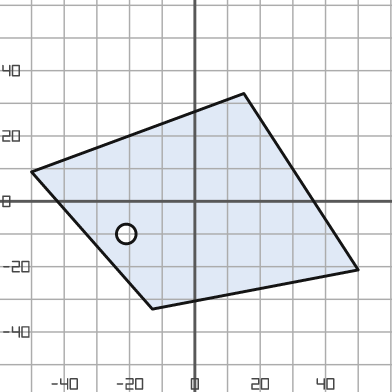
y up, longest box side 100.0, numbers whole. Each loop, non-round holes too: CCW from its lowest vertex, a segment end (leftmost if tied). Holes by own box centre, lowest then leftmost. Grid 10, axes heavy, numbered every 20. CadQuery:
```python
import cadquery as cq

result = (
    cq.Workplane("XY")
    .moveTo(-13.0, -33.0)
    .lineTo(50.0, -21.0)
    .lineTo(15.0, 33.0)
    .lineTo(-50.0, 9.0)
    .close()
    .moveTo(-21.0, -10.0)
    .circle(3.0)
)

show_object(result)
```